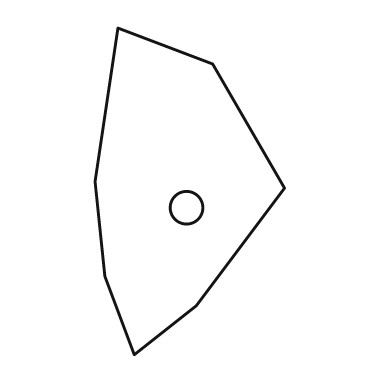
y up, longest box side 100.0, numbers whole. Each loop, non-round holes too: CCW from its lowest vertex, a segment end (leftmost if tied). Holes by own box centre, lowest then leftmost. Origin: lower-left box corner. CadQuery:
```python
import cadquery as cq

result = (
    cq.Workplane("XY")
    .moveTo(12.0, 0.0)
    .lineTo(31.0, 15.0)
    .lineTo(58.0, 51.0)
    .lineTo(36.0, 89.0)
    .lineTo(7.0, 100.0)
    .lineTo(0.0, 53.0)
    .lineTo(3.0, 24.0)
    .close()
    .moveTo(28.0, 45.0)
    .circle(5.0)
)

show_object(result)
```